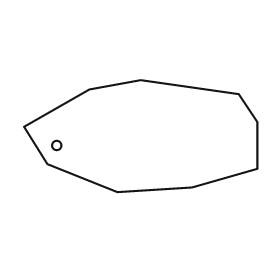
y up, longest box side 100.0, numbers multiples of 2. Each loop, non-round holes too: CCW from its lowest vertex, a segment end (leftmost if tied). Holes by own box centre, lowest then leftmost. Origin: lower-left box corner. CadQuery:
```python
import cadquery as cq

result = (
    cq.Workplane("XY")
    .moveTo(40.0, 0.0)
    .lineTo(72.0, 2.0)
    .lineTo(100.0, 10.0)
    .lineTo(100.0, 30.0)
    .lineTo(92.0, 42.0)
    .lineTo(50.0, 48.0)
    .lineTo(28.0, 44.0)
    .lineTo(0.0, 28.0)
    .lineTo(10.0, 12.0)
    .close()
    .moveTo(14.0, 20.0)
    .circle(2.0)
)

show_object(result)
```